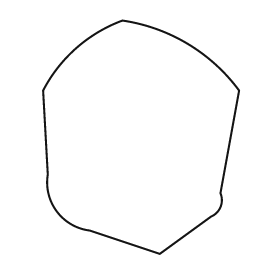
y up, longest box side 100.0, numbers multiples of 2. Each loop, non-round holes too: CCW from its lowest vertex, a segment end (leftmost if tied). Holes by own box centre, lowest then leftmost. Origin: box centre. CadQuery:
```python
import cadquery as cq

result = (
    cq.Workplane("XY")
    .moveTo(8.0, -50.0)
    .lineTo(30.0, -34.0)
    .threePointArc((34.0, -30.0), (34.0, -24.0))
    .lineTo(42.0, 20.0)
    .threePointArc((20.0, 40.0), (-8.0, 50.0))
    .threePointArc((-28.0, 38.0), (-42.0, 20.0))
    .lineTo(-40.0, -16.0)
    .threePointArc((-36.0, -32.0), (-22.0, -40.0))
    .close()
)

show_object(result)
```